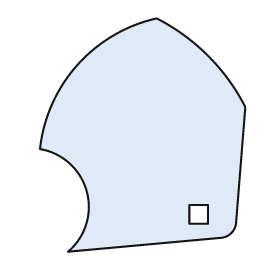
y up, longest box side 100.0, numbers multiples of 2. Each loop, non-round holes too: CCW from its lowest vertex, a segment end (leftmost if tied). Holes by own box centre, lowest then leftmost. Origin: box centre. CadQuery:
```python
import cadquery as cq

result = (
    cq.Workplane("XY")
    .moveTo(-32.0, -50.0)
    .lineTo(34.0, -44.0)
    .threePointArc((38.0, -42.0), (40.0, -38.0))
    .lineTo(44.0, 12.0)
    .threePointArc((28.0, 34.0), (6.0, 50.0))
    .threePointArc((-28.0, 30.0), (-44.0, -6.0))
    .threePointArc((-24.0, -24.0), (-32.0, -50.0))
    .close()
    .moveTo(20.0, -38.0)
    .lineTo(28.0, -38.0)
    .lineTo(28.0, -30.0)
    .lineTo(20.0, -30.0)
    .close()
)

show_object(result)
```